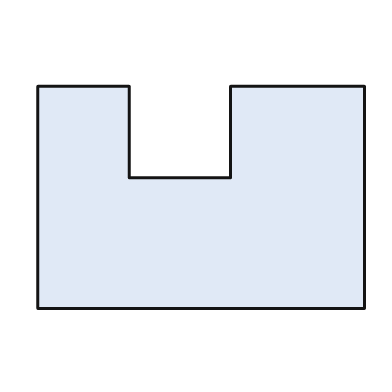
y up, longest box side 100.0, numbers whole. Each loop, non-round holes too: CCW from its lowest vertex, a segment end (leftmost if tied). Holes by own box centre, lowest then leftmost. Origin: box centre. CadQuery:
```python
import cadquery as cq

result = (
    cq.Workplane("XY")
    .moveTo(-50.0, -34.0)
    .lineTo(50.0, -34.0)
    .lineTo(50.0, 34.0)
    .lineTo(9.0, 34.0)
    .lineTo(9.0, 6.0)
    .lineTo(-22.0, 6.0)
    .lineTo(-22.0, 34.0)
    .lineTo(-50.0, 34.0)
    .close()
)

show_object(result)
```